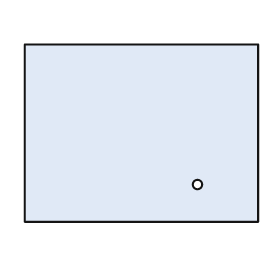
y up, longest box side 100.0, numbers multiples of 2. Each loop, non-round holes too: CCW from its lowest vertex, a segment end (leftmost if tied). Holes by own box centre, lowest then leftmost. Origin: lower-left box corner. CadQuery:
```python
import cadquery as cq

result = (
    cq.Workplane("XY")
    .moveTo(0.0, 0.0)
    .lineTo(100.0, 0.0)
    .lineTo(100.0, 76.0)
    .lineTo(0.0, 76.0)
    .close()
    .moveTo(74.0, 16.0)
    .circle(2.0)
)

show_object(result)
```